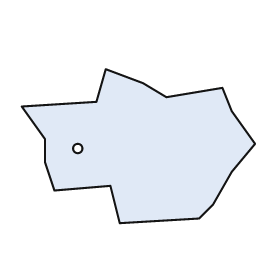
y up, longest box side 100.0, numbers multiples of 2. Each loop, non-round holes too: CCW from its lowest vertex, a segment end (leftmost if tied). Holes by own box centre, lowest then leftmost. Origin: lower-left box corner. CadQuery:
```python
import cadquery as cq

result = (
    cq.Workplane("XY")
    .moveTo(42.0, 0.0)
    .lineTo(76.0, 2.0)
    .lineTo(82.0, 8.0)
    .lineTo(90.0, 22.0)
    .lineTo(100.0, 34.0)
    .lineTo(90.0, 48.0)
    .lineTo(86.0, 58.0)
    .lineTo(62.0, 54.0)
    .lineTo(52.0, 60.0)
    .lineTo(36.0, 66.0)
    .lineTo(32.0, 52.0)
    .lineTo(0.0, 50.0)
    .lineTo(10.0, 36.0)
    .lineTo(10.0, 26.0)
    .lineTo(14.0, 14.0)
    .lineTo(38.0, 16.0)
    .close()
    .moveTo(24.0, 32.0)
    .circle(2.0)
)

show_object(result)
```